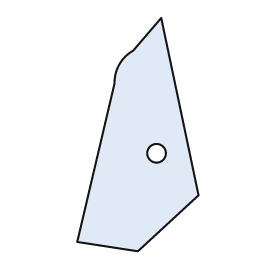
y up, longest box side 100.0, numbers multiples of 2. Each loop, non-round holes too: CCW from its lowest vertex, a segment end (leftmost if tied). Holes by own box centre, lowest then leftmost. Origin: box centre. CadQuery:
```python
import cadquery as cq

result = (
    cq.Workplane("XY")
    .moveTo(0.0, -50.0)
    .lineTo(26.0, -26.0)
    .lineTo(10.0, 50.0)
    .lineTo(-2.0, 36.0)
    .threePointArc((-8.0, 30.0), (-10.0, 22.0))
    .lineTo(-26.0, -46.0)
    .close()
    .moveTo(8.0, -8.0)
    .circle(4.0)
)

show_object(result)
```